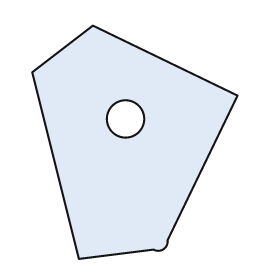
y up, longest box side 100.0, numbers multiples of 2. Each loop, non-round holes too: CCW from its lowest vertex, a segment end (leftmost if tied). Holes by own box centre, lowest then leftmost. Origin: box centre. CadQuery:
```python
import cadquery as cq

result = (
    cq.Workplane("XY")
    .moveTo(-24.0, -50.0)
    .lineTo(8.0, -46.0)
    .threePointArc((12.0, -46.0), (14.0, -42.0))
    .lineTo(44.0, 20.0)
    .lineTo(-18.0, 50.0)
    .lineTo(-44.0, 30.0)
    .close()
    .moveTo(-4.0, 10.0)
    .circle(8.0)
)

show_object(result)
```